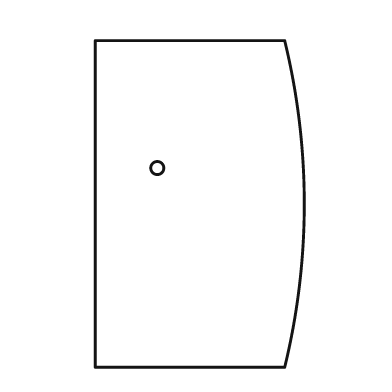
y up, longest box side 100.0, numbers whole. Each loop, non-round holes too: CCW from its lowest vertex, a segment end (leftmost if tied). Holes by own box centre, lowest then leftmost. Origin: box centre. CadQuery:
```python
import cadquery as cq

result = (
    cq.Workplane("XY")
    .moveTo(-32.0, -50.0)
    .lineTo(26.0, -50.0)
    .threePointArc((32.0, 0.0), (26.0, 50.0))
    .lineTo(-32.0, 50.0)
    .close()
    .moveTo(-13.0, 11.0)
    .circle(2.0)
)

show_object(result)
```